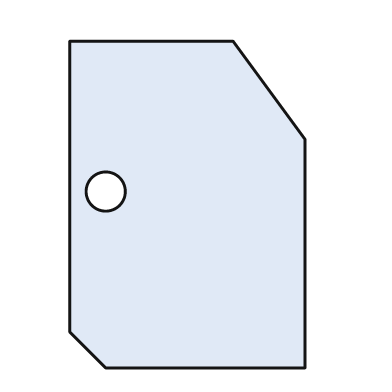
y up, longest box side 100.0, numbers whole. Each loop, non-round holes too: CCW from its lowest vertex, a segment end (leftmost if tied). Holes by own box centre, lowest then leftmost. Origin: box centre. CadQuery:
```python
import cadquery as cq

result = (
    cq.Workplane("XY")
    .moveTo(-25.0, -50.0)
    .lineTo(36.0, -50.0)
    .lineTo(36.0, 20.0)
    .lineTo(14.0, 50.0)
    .lineTo(-36.0, 50.0)
    .lineTo(-36.0, -39.0)
    .close()
    .moveTo(-25.0, 4.0)
    .circle(6.0)
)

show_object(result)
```